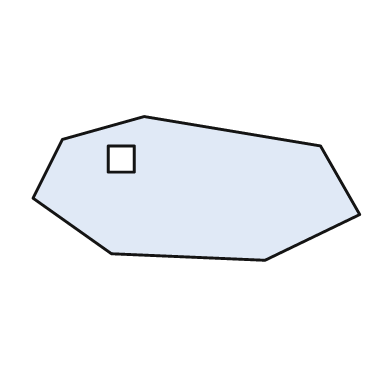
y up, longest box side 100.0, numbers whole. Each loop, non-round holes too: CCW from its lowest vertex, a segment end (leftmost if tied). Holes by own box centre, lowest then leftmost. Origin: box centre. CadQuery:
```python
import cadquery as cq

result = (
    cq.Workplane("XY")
    .moveTo(21.0, -22.0)
    .lineTo(50.0, -8.0)
    .lineTo(38.0, 13.0)
    .lineTo(-16.0, 22.0)
    .lineTo(-41.0, 15.0)
    .lineTo(-50.0, -3.0)
    .lineTo(-26.0, -20.0)
    .close()
    .moveTo(-27.0, 5.0)
    .lineTo(-19.0, 5.0)
    .lineTo(-19.0, 13.0)
    .lineTo(-27.0, 13.0)
    .close()
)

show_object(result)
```